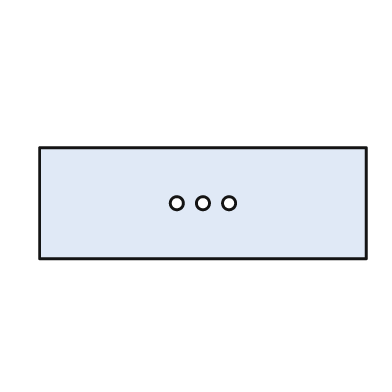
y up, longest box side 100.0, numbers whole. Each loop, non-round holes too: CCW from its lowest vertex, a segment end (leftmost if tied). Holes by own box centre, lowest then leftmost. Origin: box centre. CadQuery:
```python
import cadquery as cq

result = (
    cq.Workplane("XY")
    .moveTo(-50.0, -17.0)
    .lineTo(50.0, -17.0)
    .lineTo(50.0, 17.0)
    .lineTo(-50.0, 17.0)
    .close()
    .moveTo(-8.0, 0.0)
    .circle(2.0)
    .moveTo(0.0, 0.0)
    .circle(2.0)
    .moveTo(8.0, 0.0)
    .circle(2.0)
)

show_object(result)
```